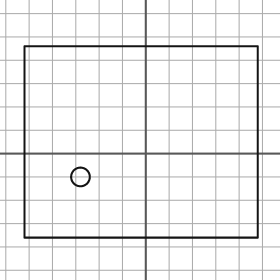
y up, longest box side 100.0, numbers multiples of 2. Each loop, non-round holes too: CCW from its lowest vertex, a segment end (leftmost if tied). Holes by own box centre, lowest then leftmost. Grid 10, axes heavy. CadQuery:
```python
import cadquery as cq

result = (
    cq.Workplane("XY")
    .moveTo(-52.0, -36.0)
    .lineTo(48.0, -36.0)
    .lineTo(48.0, 46.0)
    .lineTo(-52.0, 46.0)
    .close()
    .moveTo(-28.0, -10.0)
    .circle(4.0)
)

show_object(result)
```